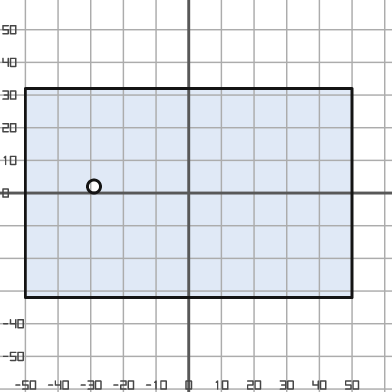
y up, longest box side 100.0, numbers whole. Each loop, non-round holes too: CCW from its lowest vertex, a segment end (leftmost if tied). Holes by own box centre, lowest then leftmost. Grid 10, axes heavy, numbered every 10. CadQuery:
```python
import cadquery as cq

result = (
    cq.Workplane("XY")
    .moveTo(-50.0, -32.0)
    .lineTo(50.0, -32.0)
    .lineTo(50.0, 32.0)
    .lineTo(-50.0, 32.0)
    .close()
    .moveTo(-29.0, 2.0)
    .circle(2.0)
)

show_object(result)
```